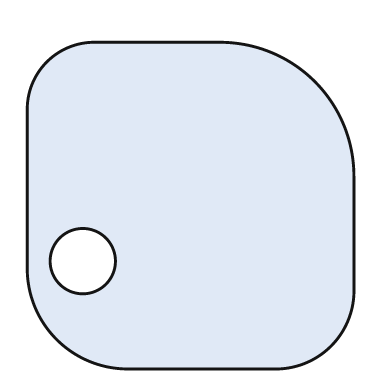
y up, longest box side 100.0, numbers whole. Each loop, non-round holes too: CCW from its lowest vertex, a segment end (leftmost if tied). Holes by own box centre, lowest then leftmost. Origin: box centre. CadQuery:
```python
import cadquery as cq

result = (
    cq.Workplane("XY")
    .moveTo(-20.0, -50.0)
    .lineTo(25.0, -50.0)
    .threePointArc((43.0, -43.0), (50.0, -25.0))
    .lineTo(50.0, 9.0)
    .threePointArc((38.0, 38.0), (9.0, 50.0))
    .lineTo(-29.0, 50.0)
    .threePointArc((-44.0, 44.0), (-50.0, 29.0))
    .lineTo(-50.0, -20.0)
    .threePointArc((-41.0, -41.0), (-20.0, -50.0))
    .close()
    .moveTo(-33.0, -17.0)
    .circle(10.0)
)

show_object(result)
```